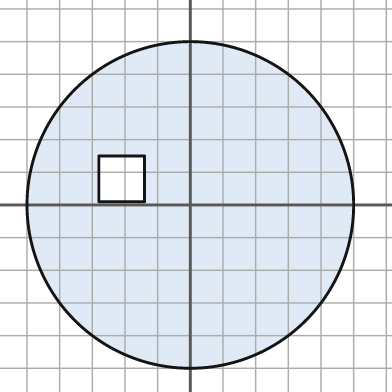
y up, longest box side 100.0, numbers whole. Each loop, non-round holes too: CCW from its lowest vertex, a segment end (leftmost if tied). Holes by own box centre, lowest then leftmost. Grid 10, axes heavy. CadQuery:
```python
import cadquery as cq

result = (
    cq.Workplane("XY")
    .moveTo(0.0, 0.0)
    .circle(50.0)
    .moveTo(-28.0, 1.0)
    .lineTo(-14.0, 1.0)
    .lineTo(-14.0, 15.0)
    .lineTo(-28.0, 15.0)
    .close()
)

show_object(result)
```